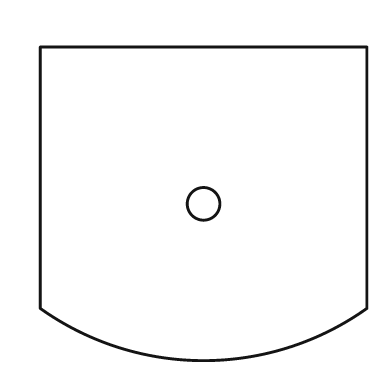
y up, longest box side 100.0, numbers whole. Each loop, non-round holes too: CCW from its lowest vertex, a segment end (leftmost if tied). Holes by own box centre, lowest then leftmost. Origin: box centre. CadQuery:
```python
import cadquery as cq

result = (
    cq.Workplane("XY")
    .moveTo(-50.0, -32.0)
    .threePointArc((0.0, -48.0), (50.0, -32.0))
    .lineTo(50.0, 48.0)
    .lineTo(-50.0, 48.0)
    .close()
    .moveTo(0.0, 0.0)
    .circle(5.0)
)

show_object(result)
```